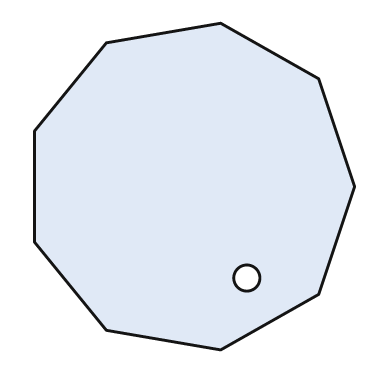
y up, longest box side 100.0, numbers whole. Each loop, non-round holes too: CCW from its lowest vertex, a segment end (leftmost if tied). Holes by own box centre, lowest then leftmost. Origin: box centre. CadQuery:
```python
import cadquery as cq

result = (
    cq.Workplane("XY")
    .moveTo(8.0, -50.0)
    .lineTo(38.0, -33.0)
    .lineTo(49.0, 0.0)
    .lineTo(38.0, 33.0)
    .lineTo(8.0, 50.0)
    .lineTo(-27.0, 44.0)
    .lineTo(-49.0, 17.0)
    .lineTo(-49.0, -17.0)
    .lineTo(-27.0, -44.0)
    .close()
    .moveTo(16.0, -28.0)
    .circle(4.0)
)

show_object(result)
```